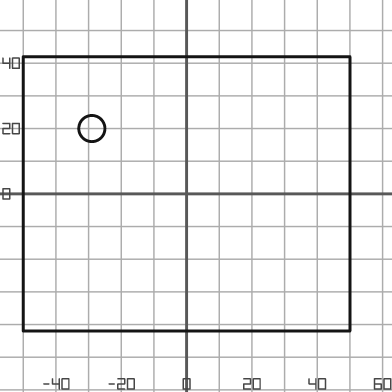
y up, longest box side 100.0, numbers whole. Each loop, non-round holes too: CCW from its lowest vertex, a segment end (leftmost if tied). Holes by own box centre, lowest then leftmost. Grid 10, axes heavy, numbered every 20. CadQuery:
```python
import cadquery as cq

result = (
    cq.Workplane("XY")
    .moveTo(-50.0, -42.0)
    .lineTo(50.0, -42.0)
    .lineTo(50.0, 42.0)
    .lineTo(-50.0, 42.0)
    .close()
    .moveTo(-29.0, 20.0)
    .circle(4.0)
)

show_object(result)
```